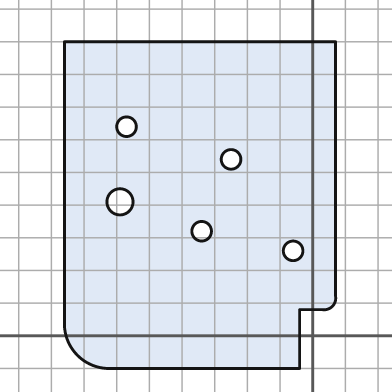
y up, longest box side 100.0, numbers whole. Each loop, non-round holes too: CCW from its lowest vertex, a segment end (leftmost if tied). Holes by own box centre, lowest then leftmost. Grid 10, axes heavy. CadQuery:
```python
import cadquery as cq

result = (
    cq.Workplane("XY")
    .moveTo(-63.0, -10.0)
    .lineTo(-4.0, -10.0)
    .lineTo(-4.0, 8.0)
    .lineTo(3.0, 8.0)
    .threePointArc((6.0, 9.0), (7.0, 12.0))
    .lineTo(7.0, 90.0)
    .lineTo(-76.0, 90.0)
    .lineTo(-76.0, 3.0)
    .threePointArc((-72.0, -6.0), (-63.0, -10.0))
    .close()
    .moveTo(-6.0, 26.0)
    .circle(3.0)
    .moveTo(-34.0, 32.0)
    .circle(3.0)
    .moveTo(-59.0, 41.0)
    .circle(4.0)
    .moveTo(-25.0, 54.0)
    .circle(3.0)
    .moveTo(-57.0, 64.0)
    .circle(3.0)
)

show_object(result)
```